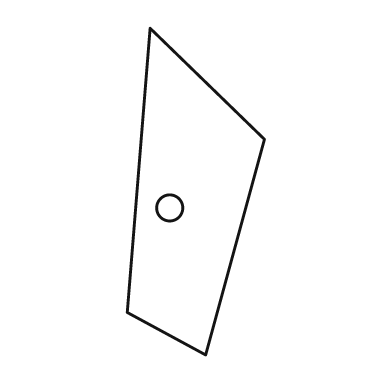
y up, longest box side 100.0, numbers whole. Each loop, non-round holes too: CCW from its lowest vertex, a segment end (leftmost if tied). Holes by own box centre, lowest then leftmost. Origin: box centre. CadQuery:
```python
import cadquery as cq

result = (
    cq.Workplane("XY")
    .moveTo(3.0, -50.0)
    .lineTo(21.0, 16.0)
    .lineTo(-14.0, 50.0)
    .lineTo(-21.0, -37.0)
    .close()
    .moveTo(-8.0, -5.0)
    .circle(4.0)
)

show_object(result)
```